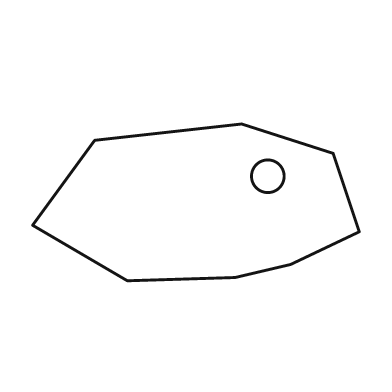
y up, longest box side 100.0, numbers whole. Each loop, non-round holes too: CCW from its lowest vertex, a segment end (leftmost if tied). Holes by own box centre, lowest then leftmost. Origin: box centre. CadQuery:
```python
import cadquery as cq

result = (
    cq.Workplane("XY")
    .moveTo(-21.0, -24.0)
    .lineTo(12.0, -23.0)
    .lineTo(29.0, -19.0)
    .lineTo(50.0, -9.0)
    .lineTo(42.0, 15.0)
    .lineTo(14.0, 24.0)
    .lineTo(-31.0, 19.0)
    .lineTo(-50.0, -7.0)
    .close()
    .moveTo(22.0, 8.0)
    .circle(5.0)
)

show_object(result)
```